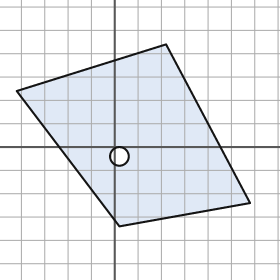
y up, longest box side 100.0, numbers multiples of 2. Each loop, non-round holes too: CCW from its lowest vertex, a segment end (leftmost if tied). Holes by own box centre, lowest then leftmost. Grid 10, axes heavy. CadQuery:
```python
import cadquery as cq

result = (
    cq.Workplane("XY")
    .moveTo(2.0, -34.0)
    .lineTo(58.0, -24.0)
    .lineTo(22.0, 44.0)
    .lineTo(-42.0, 24.0)
    .close()
    .moveTo(2.0, -4.0)
    .circle(4.0)
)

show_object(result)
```